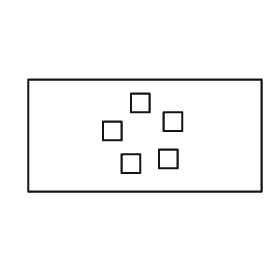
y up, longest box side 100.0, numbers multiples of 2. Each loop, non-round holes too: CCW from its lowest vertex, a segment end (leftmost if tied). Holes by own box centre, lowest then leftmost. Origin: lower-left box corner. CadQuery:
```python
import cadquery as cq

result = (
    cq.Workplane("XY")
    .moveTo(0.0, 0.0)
    .lineTo(100.0, 0.0)
    .lineTo(100.0, 48.0)
    .lineTo(0.0, 48.0)
    .close()
    .moveTo(40.0, 8.0)
    .lineTo(48.0, 8.0)
    .lineTo(48.0, 16.0)
    .lineTo(40.0, 16.0)
    .close()
    .moveTo(56.0, 10.0)
    .lineTo(64.0, 10.0)
    .lineTo(64.0, 18.0)
    .lineTo(56.0, 18.0)
    .close()
    .moveTo(32.0, 22.0)
    .lineTo(40.0, 22.0)
    .lineTo(40.0, 30.0)
    .lineTo(32.0, 30.0)
    .close()
    .moveTo(58.0, 26.0)
    .lineTo(66.0, 26.0)
    .lineTo(66.0, 34.0)
    .lineTo(58.0, 34.0)
    .close()
    .moveTo(44.0, 34.0)
    .lineTo(52.0, 34.0)
    .lineTo(52.0, 42.0)
    .lineTo(44.0, 42.0)
    .close()
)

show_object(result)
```